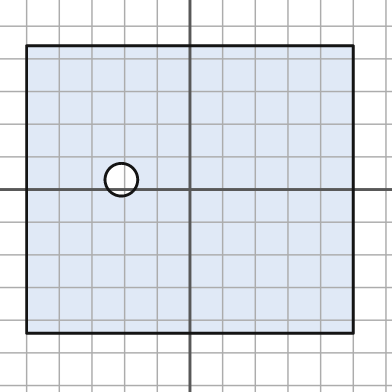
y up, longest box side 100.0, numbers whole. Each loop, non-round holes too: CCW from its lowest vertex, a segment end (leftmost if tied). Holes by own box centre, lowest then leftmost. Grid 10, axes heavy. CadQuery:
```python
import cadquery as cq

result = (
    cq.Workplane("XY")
    .moveTo(-50.0, -44.0)
    .lineTo(50.0, -44.0)
    .lineTo(50.0, 44.0)
    .lineTo(-50.0, 44.0)
    .close()
    .moveTo(-21.0, 3.0)
    .circle(5.0)
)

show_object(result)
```